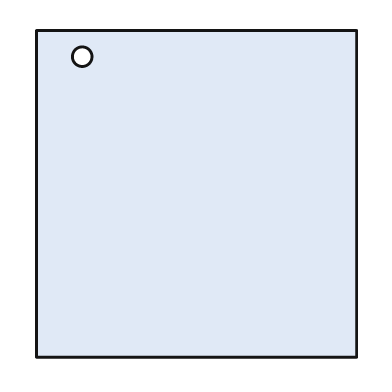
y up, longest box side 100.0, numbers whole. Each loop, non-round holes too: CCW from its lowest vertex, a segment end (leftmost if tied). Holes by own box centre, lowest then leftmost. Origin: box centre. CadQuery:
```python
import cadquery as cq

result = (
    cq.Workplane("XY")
    .moveTo(-49.0, -50.0)
    .lineTo(49.0, -50.0)
    .lineTo(49.0, 50.0)
    .lineTo(-49.0, 50.0)
    .close()
    .moveTo(-35.0, 42.0)
    .circle(3.0)
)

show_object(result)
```